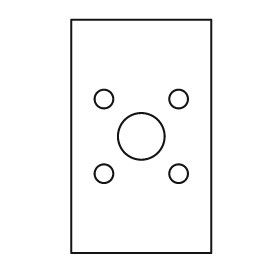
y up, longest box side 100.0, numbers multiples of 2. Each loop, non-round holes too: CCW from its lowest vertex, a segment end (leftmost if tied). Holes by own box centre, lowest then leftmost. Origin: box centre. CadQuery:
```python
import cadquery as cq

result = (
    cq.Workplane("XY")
    .moveTo(-30.0, -50.0)
    .lineTo(30.0, -50.0)
    .lineTo(30.0, 50.0)
    .lineTo(-30.0, 50.0)
    .close()
    .moveTo(-16.0, -16.0)
    .circle(4.0)
    .moveTo(16.0, -16.0)
    .circle(4.0)
    .moveTo(0.0, 0.0)
    .circle(10.0)
    .moveTo(-16.0, 16.0)
    .circle(4.0)
    .moveTo(16.0, 16.0)
    .circle(4.0)
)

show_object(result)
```